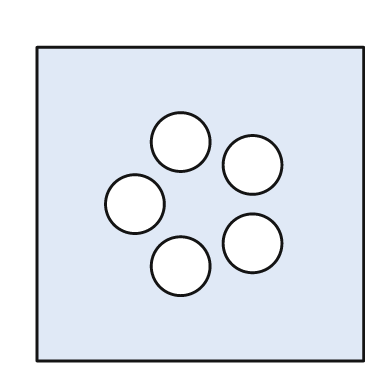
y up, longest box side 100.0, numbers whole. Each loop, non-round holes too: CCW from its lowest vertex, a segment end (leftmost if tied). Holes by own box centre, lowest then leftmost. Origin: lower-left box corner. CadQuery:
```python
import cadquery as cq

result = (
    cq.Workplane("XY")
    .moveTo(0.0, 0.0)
    .lineTo(100.0, 0.0)
    .lineTo(100.0, 96.0)
    .lineTo(0.0, 96.0)
    .close()
    .moveTo(44.0, 29.0)
    .circle(9.0)
    .moveTo(66.0, 36.0)
    .circle(9.0)
    .moveTo(30.0, 48.0)
    .circle(9.0)
    .moveTo(66.0, 60.0)
    .circle(9.0)
    .moveTo(44.0, 67.0)
    .circle(9.0)
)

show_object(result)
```